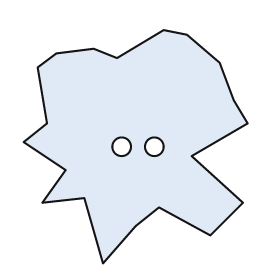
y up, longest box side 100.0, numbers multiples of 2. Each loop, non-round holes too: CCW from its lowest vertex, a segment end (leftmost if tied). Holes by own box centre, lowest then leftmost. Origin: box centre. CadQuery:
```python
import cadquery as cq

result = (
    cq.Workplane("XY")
    .moveTo(-14.0, -50.0)
    .lineTo(0.0, -34.0)
    .lineTo(10.0, -26.0)
    .lineTo(32.0, -38.0)
    .lineTo(46.0, -24.0)
    .lineTo(24.0, -4.0)
    .lineTo(48.0, 10.0)
    .lineTo(42.0, 20.0)
    .lineTo(36.0, 36.0)
    .lineTo(22.0, 48.0)
    .lineTo(12.0, 50.0)
    .lineTo(-8.0, 38.0)
    .lineTo(-18.0, 42.0)
    .lineTo(-34.0, 40.0)
    .lineTo(-42.0, 34.0)
    .lineTo(-38.0, 10.0)
    .lineTo(-48.0, 2.0)
    .lineTo(-30.0, -10.0)
    .lineTo(-40.0, -24.0)
    .lineTo(-22.0, -22.0)
    .close()
    .moveTo(-6.0, 0.0)
    .circle(4.0)
    .moveTo(8.0, 0.0)
    .circle(4.0)
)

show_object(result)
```